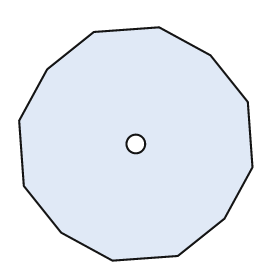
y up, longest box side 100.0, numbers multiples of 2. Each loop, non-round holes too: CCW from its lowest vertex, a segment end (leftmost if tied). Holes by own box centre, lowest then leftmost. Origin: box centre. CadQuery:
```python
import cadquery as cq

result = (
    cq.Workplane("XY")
    .moveTo(-10.0, -50.0)
    .lineTo(18.0, -48.0)
    .lineTo(38.0, -32.0)
    .lineTo(50.0, -10.0)
    .lineTo(48.0, 18.0)
    .lineTo(32.0, 38.0)
    .lineTo(10.0, 50.0)
    .lineTo(-18.0, 48.0)
    .lineTo(-38.0, 32.0)
    .lineTo(-50.0, 10.0)
    .lineTo(-48.0, -18.0)
    .lineTo(-32.0, -38.0)
    .close()
    .moveTo(0.0, 0.0)
    .circle(4.0)
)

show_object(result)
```